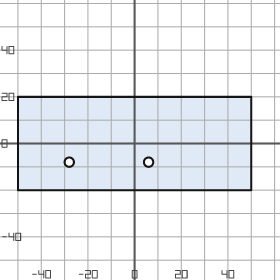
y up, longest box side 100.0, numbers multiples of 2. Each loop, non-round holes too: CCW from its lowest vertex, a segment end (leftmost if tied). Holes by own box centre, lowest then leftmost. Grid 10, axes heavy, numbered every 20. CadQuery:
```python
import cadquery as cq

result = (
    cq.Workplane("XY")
    .moveTo(-50.0, -20.0)
    .lineTo(50.0, -20.0)
    .lineTo(50.0, 20.0)
    .lineTo(-50.0, 20.0)
    .close()
    .moveTo(-28.0, -8.0)
    .circle(2.0)
    .moveTo(6.0, -8.0)
    .circle(2.0)
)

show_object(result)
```